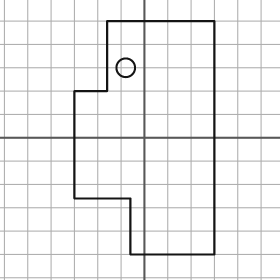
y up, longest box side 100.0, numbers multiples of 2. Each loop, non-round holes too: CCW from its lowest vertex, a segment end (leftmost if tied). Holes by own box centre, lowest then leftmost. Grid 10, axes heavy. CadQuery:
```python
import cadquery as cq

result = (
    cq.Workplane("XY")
    .moveTo(-6.0, -50.0)
    .lineTo(30.0, -50.0)
    .lineTo(30.0, 50.0)
    .lineTo(-16.0, 50.0)
    .lineTo(-16.0, 20.0)
    .lineTo(-30.0, 20.0)
    .lineTo(-30.0, -26.0)
    .lineTo(-6.0, -26.0)
    .close()
    .moveTo(-8.0, 30.0)
    .circle(4.0)
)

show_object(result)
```